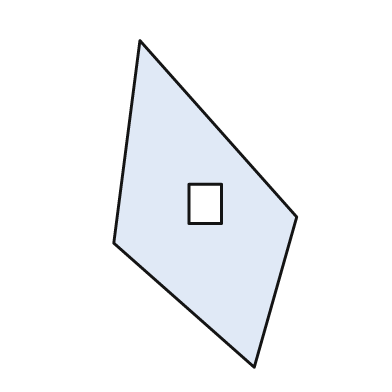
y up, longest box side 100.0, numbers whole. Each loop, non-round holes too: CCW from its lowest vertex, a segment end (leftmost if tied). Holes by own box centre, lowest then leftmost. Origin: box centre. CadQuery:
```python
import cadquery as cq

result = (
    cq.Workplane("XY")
    .moveTo(15.0, -50.0)
    .lineTo(28.0, -4.0)
    .lineTo(-20.0, 50.0)
    .lineTo(-28.0, -12.0)
    .close()
    .moveTo(-5.0, -6.0)
    .lineTo(5.0, -6.0)
    .lineTo(5.0, 6.0)
    .lineTo(-5.0, 6.0)
    .close()
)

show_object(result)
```